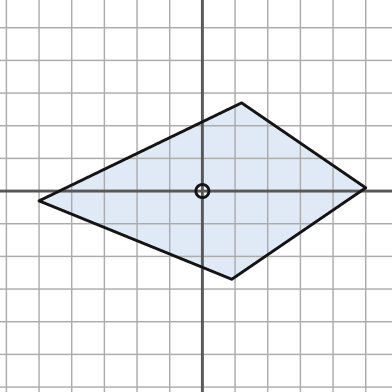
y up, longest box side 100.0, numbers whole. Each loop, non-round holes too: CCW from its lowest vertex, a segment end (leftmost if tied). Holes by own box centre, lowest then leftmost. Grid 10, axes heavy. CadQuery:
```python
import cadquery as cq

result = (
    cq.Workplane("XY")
    .moveTo(9.0, -27.0)
    .lineTo(50.0, 1.0)
    .lineTo(12.0, 27.0)
    .lineTo(-50.0, -3.0)
    .close()
    .moveTo(0.0, 0.0)
    .circle(2.0)
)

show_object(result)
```